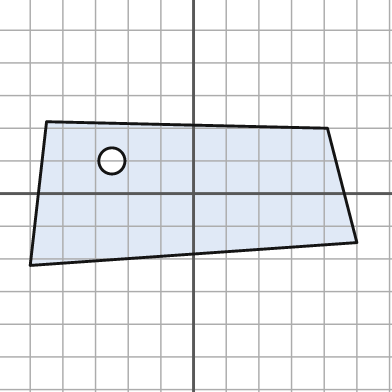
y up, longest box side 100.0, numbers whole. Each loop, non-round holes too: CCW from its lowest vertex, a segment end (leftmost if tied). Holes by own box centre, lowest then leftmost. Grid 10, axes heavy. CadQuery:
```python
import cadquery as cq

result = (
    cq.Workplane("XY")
    .moveTo(-50.0, -22.0)
    .lineTo(50.0, -15.0)
    .lineTo(41.0, 20.0)
    .lineTo(-45.0, 22.0)
    .close()
    .moveTo(-25.0, 10.0)
    .circle(4.0)
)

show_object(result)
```